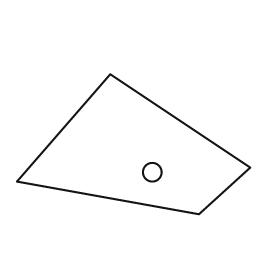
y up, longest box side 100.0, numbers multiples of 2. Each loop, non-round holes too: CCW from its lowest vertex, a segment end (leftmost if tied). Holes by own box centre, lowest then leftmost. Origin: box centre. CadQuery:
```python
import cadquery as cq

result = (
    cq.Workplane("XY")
    .moveTo(28.0, -30.0)
    .lineTo(50.0, -10.0)
    .lineTo(-10.0, 30.0)
    .lineTo(-50.0, -16.0)
    .close()
    .moveTo(8.0, -12.0)
    .circle(4.0)
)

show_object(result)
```